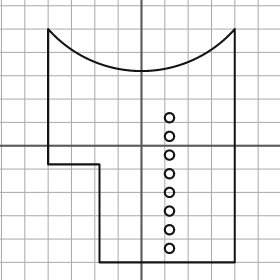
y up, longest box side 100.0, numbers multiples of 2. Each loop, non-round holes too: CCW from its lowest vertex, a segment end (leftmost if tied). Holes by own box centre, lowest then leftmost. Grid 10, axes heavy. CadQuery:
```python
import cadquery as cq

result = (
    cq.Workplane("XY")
    .moveTo(-18.0, -50.0)
    .lineTo(40.0, -50.0)
    .lineTo(40.0, 50.0)
    .threePointArc((0.0, 32.0), (-40.0, 50.0))
    .lineTo(-40.0, -8.0)
    .lineTo(-18.0, -8.0)
    .close()
    .moveTo(12.0, -44.0)
    .circle(2.0)
    .moveTo(12.0, -36.0)
    .circle(2.0)
    .moveTo(12.0, -28.0)
    .circle(2.0)
    .moveTo(12.0, -20.0)
    .circle(2.0)
    .moveTo(12.0, -12.0)
    .circle(2.0)
    .moveTo(12.0, -4.0)
    .circle(2.0)
    .moveTo(12.0, 4.0)
    .circle(2.0)
    .moveTo(12.0, 12.0)
    .circle(2.0)
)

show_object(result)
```